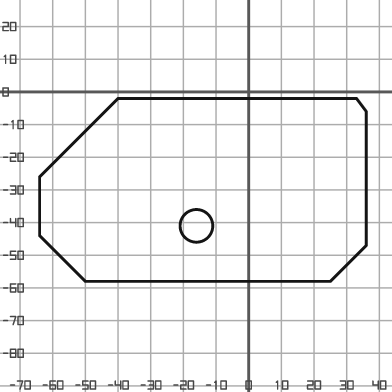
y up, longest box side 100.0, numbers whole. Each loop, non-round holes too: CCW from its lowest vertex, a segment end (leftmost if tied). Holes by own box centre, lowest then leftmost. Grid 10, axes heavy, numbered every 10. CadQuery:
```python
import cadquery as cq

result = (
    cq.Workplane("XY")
    .moveTo(-50.0, -58.0)
    .lineTo(25.0, -58.0)
    .lineTo(36.0, -47.0)
    .lineTo(36.0, -6.0)
    .lineTo(33.0, -2.0)
    .lineTo(-40.0, -2.0)
    .lineTo(-64.0, -26.0)
    .lineTo(-64.0, -44.0)
    .close()
    .moveTo(-16.0, -41.0)
    .circle(5.0)
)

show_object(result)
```